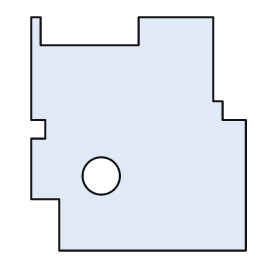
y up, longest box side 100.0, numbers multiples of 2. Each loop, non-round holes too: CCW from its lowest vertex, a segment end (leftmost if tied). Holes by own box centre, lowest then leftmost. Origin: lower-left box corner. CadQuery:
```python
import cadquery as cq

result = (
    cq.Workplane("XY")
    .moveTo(12.0, 0.0)
    .lineTo(92.0, 0.0)
    .lineTo(92.0, 56.0)
    .lineTo(82.0, 56.0)
    .lineTo(82.0, 64.0)
    .lineTo(78.0, 64.0)
    .lineTo(78.0, 100.0)
    .lineTo(46.0, 100.0)
    .lineTo(46.0, 88.0)
    .lineTo(4.0, 88.0)
    .lineTo(4.0, 100.0)
    .lineTo(0.0, 100.0)
    .lineTo(0.0, 56.0)
    .lineTo(6.0, 56.0)
    .lineTo(6.0, 48.0)
    .lineTo(0.0, 48.0)
    .lineTo(0.0, 22.0)
    .lineTo(12.0, 22.0)
    .close()
    .moveTo(30.0, 32.0)
    .circle(8.0)
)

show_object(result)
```